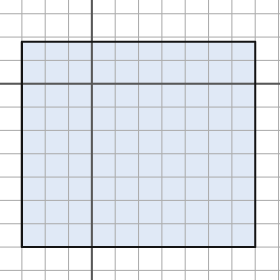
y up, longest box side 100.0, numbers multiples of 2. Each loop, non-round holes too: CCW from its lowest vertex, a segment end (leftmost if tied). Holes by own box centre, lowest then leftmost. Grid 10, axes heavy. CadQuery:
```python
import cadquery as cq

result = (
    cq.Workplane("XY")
    .moveTo(-30.0, -70.0)
    .lineTo(70.0, -70.0)
    .lineTo(70.0, 18.0)
    .lineTo(-30.0, 18.0)
    .close()
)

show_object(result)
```